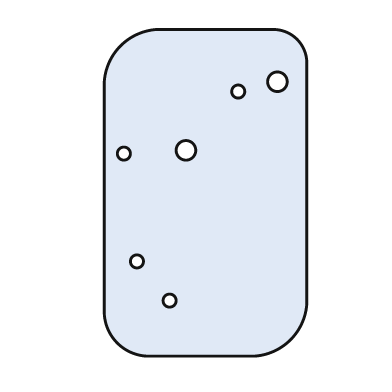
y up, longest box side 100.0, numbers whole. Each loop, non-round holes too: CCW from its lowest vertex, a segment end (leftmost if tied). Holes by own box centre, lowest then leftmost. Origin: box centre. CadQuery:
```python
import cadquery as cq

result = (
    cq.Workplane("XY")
    .moveTo(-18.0, -50.0)
    .lineTo(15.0, -50.0)
    .threePointArc((26.0, -45.0), (31.0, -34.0))
    .lineTo(31.0, 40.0)
    .threePointArc((28.0, 47.0), (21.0, 50.0))
    .lineTo(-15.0, 50.0)
    .threePointArc((-26.0, 45.0), (-31.0, 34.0))
    .lineTo(-31.0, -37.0)
    .threePointArc((-27.0, -46.0), (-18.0, -50.0))
    .close()
    .moveTo(-11.0, -33.0)
    .circle(2.0)
    .moveTo(-21.0, -21.0)
    .circle(2.0)
    .moveTo(-25.0, 12.0)
    .circle(2.0)
    .moveTo(-6.0, 13.0)
    .circle(3.0)
    .moveTo(10.0, 31.0)
    .circle(2.0)
    .moveTo(22.0, 34.0)
    .circle(3.0)
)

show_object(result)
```